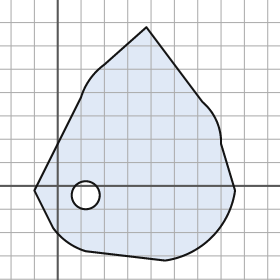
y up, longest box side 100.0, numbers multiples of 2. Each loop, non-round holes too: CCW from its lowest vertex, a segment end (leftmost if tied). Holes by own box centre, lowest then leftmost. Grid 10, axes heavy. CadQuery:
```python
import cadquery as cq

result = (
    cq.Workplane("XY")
    .moveTo(46.0, -32.0)
    .threePointArc((66.0, -22.0), (76.0, -2.0))
    .lineTo(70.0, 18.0)
    .threePointArc((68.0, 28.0), (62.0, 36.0))
    .lineTo(38.0, 68.0)
    .lineTo(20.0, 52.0)
    .threePointArc((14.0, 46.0), (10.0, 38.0))
    .lineTo(-10.0, -2.0)
    .lineTo(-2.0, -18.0)
    .threePointArc((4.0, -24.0), (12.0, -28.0))
    .close()
    .moveTo(12.0, -4.0)
    .circle(6.0)
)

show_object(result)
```